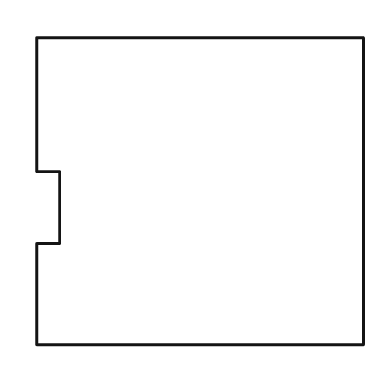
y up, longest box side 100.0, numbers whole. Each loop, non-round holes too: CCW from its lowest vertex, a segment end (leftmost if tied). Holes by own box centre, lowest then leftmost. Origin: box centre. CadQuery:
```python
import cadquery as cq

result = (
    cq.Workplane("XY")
    .moveTo(-50.0, -47.0)
    .lineTo(50.0, -47.0)
    .lineTo(50.0, 47.0)
    .lineTo(-50.0, 47.0)
    .lineTo(-50.0, 6.0)
    .lineTo(-43.0, 6.0)
    .lineTo(-43.0, -16.0)
    .lineTo(-50.0, -16.0)
    .close()
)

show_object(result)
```